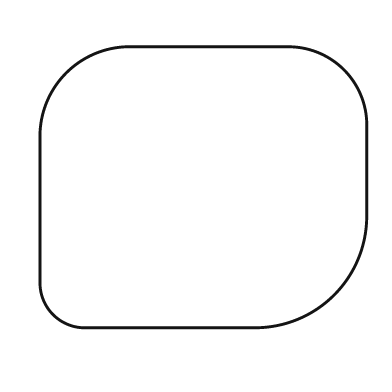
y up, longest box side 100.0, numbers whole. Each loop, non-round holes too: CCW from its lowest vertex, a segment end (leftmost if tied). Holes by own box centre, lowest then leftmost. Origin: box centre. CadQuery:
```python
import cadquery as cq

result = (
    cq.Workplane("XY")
    .moveTo(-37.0, -43.0)
    .lineTo(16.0, -43.0)
    .threePointArc((40.0, -33.0), (50.0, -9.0))
    .lineTo(50.0, 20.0)
    .threePointArc((43.0, 36.0), (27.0, 43.0))
    .lineTo(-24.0, 43.0)
    .threePointArc((-42.0, 35.0), (-50.0, 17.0))
    .lineTo(-50.0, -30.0)
    .threePointArc((-46.0, -39.0), (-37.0, -43.0))
    .close()
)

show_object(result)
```